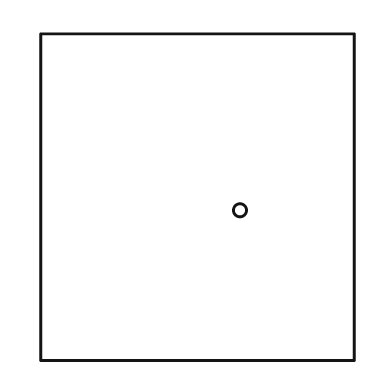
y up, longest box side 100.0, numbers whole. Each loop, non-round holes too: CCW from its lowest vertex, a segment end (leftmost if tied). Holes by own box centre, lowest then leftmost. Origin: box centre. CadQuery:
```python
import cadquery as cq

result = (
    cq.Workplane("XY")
    .moveTo(-48.0, -50.0)
    .lineTo(48.0, -50.0)
    .lineTo(48.0, 50.0)
    .lineTo(-48.0, 50.0)
    .close()
    .moveTo(13.0, -4.0)
    .circle(2.0)
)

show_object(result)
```